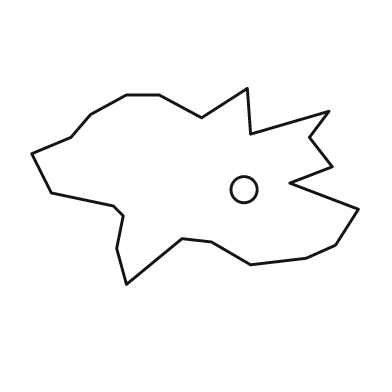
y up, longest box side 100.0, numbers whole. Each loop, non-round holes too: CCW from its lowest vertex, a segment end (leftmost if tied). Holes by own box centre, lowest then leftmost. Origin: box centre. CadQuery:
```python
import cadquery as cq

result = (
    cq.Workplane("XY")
    .moveTo(-21.0, -30.0)
    .lineTo(-4.0, -16.0)
    .lineTo(5.0, -17.0)
    .lineTo(17.0, -24.0)
    .lineTo(34.0, -22.0)
    .lineTo(43.0, -18.0)
    .lineTo(50.0, -7.0)
    .lineTo(29.0, 1.0)
    .lineTo(42.0, 6.0)
    .lineTo(35.0, 15.0)
    .lineTo(41.0, 23.0)
    .lineTo(17.0, 16.0)
    .lineTo(16.0, 30.0)
    .lineTo(2.0, 21.0)
    .lineTo(-11.0, 28.0)
    .lineTo(-21.0, 28.0)
    .lineTo(-32.0, 22.0)
    .lineTo(-38.0, 15.0)
    .lineTo(-50.0, 10.0)
    .lineTo(-44.0, -2.0)
    .lineTo(-25.0, -6.0)
    .lineTo(-22.0, -9.0)
    .lineTo(-24.0, -19.0)
    .close()
    .moveTo(15.0, -1.0)
    .circle(4.0)
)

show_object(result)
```